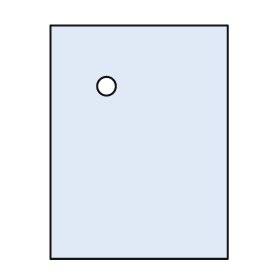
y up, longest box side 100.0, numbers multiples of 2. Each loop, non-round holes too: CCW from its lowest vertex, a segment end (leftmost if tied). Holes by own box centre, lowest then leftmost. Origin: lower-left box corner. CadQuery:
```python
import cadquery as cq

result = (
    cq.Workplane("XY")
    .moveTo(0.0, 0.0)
    .lineTo(76.0, 0.0)
    .lineTo(76.0, 100.0)
    .lineTo(0.0, 100.0)
    .close()
    .moveTo(24.0, 74.0)
    .circle(4.0)
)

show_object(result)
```